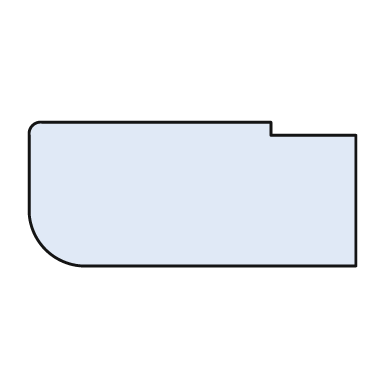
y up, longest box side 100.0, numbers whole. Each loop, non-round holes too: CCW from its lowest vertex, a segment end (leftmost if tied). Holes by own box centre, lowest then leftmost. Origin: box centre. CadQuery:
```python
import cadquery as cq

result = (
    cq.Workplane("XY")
    .moveTo(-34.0, -22.0)
    .lineTo(50.0, -22.0)
    .lineTo(50.0, 18.0)
    .lineTo(24.0, 18.0)
    .lineTo(24.0, 22.0)
    .lineTo(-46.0, 22.0)
    .threePointArc((-49.0, 21.0), (-50.0, 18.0))
    .lineTo(-50.0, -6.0)
    .threePointArc((-45.0, -17.0), (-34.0, -22.0))
    .close()
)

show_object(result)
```